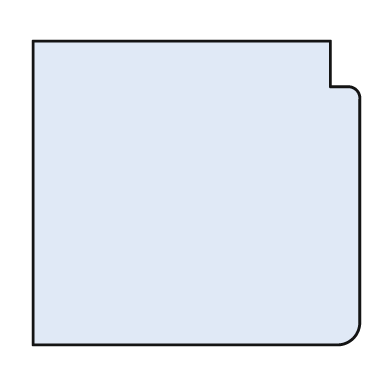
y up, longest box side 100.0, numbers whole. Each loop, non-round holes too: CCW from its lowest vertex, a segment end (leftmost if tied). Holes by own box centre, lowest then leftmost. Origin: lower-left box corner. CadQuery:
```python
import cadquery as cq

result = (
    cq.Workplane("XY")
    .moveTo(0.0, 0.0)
    .lineTo(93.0, 0.0)
    .threePointArc((98.0, 2.0), (100.0, 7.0))
    .lineTo(100.0, 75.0)
    .threePointArc((99.0, 78.0), (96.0, 79.0))
    .lineTo(91.0, 79.0)
    .lineTo(91.0, 93.0)
    .lineTo(0.0, 93.0)
    .close()
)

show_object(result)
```